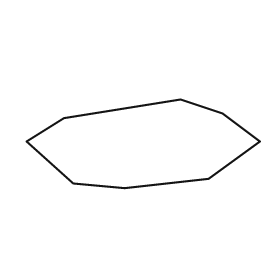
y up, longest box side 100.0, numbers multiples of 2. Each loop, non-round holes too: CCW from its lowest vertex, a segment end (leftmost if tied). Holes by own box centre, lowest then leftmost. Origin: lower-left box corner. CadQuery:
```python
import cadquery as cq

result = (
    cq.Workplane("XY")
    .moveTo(42.0, 0.0)
    .lineTo(78.0, 4.0)
    .lineTo(100.0, 20.0)
    .lineTo(84.0, 32.0)
    .lineTo(66.0, 38.0)
    .lineTo(16.0, 30.0)
    .lineTo(0.0, 20.0)
    .lineTo(20.0, 2.0)
    .close()
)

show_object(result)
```